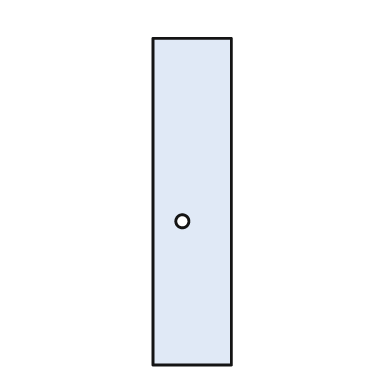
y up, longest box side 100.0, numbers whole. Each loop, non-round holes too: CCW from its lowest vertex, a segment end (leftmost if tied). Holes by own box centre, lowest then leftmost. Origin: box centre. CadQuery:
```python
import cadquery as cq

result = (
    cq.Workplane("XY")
    .moveTo(-12.0, -50.0)
    .lineTo(12.0, -50.0)
    .lineTo(12.0, 50.0)
    .lineTo(-12.0, 50.0)
    .close()
    .moveTo(-3.0, -6.0)
    .circle(2.0)
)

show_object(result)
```